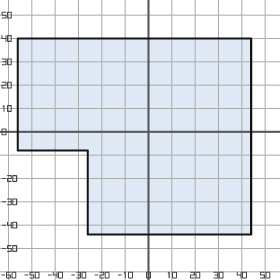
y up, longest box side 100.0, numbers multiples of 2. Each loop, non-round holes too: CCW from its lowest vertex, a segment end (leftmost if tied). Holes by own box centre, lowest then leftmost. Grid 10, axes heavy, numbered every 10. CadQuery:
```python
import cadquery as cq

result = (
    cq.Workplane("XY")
    .moveTo(-26.0, -44.0)
    .lineTo(44.0, -44.0)
    .lineTo(44.0, 40.0)
    .lineTo(-56.0, 40.0)
    .lineTo(-56.0, -8.0)
    .lineTo(-26.0, -8.0)
    .close()
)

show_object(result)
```